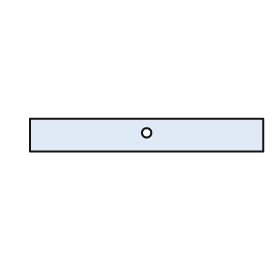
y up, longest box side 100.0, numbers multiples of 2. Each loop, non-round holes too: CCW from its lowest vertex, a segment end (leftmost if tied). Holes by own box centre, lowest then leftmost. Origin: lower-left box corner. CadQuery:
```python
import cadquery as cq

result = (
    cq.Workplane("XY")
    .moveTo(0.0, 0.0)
    .lineTo(100.0, 0.0)
    .lineTo(100.0, 14.0)
    .lineTo(0.0, 14.0)
    .close()
    .moveTo(50.0, 8.0)
    .circle(2.0)
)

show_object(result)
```